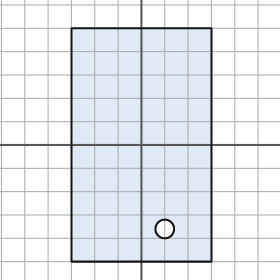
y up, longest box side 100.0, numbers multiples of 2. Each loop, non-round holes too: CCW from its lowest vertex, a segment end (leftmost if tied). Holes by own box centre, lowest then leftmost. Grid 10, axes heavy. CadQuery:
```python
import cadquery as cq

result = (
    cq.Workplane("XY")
    .moveTo(-30.0, -50.0)
    .lineTo(30.0, -50.0)
    .lineTo(30.0, 50.0)
    .lineTo(-30.0, 50.0)
    .close()
    .moveTo(10.0, -36.0)
    .circle(4.0)
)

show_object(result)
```